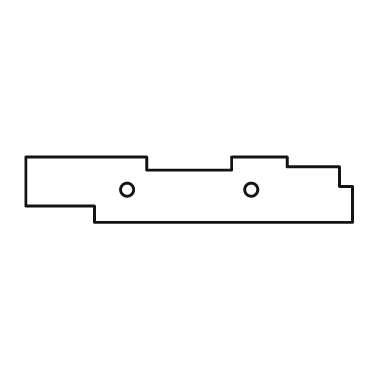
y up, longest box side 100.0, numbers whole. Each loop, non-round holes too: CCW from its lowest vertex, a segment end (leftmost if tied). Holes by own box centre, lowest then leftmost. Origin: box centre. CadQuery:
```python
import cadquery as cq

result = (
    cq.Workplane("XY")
    .moveTo(-29.0, -10.0)
    .lineTo(50.0, -10.0)
    .lineTo(50.0, 1.0)
    .lineTo(46.0, 1.0)
    .lineTo(46.0, 7.0)
    .lineTo(30.0, 7.0)
    .lineTo(30.0, 10.0)
    .lineTo(13.0, 10.0)
    .lineTo(13.0, 6.0)
    .lineTo(-13.0, 6.0)
    .lineTo(-13.0, 10.0)
    .lineTo(-50.0, 10.0)
    .lineTo(-50.0, -5.0)
    .lineTo(-29.0, -5.0)
    .close()
    .moveTo(-19.0, 0.0)
    .circle(2.0)
    .moveTo(19.0, 0.0)
    .circle(2.0)
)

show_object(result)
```